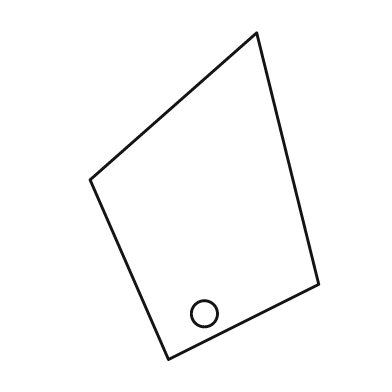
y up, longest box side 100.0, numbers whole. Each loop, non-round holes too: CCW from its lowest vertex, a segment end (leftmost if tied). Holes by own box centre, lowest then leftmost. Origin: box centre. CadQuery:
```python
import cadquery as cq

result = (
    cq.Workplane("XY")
    .moveTo(-11.0, -50.0)
    .lineTo(35.0, -27.0)
    .lineTo(16.0, 50.0)
    .lineTo(-35.0, 5.0)
    .close()
    .moveTo(0.0, -36.0)
    .circle(4.0)
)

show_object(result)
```